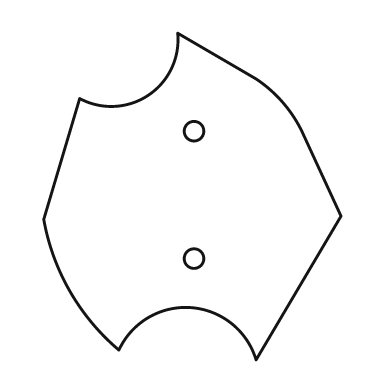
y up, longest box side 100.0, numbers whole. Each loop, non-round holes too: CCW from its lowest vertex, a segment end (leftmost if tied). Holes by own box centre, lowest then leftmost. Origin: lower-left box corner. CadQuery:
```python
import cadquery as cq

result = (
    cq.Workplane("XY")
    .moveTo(65.0, 0.0)
    .lineTo(91.0, 44.0)
    .lineTo(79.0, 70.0)
    .threePointArc((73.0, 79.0), (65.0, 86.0))
    .lineTo(41.0, 100.0)
    .threePointArc((32.0, 81.0), (11.0, 80.0))
    .lineTo(0.0, 43.0)
    .threePointArc((8.0, 21.0), (23.0, 3.0))
    .threePointArc((45.0, 16.0), (65.0, 0.0))
    .close()
    .moveTo(46.0, 31.0)
    .circle(3.0)
    .moveTo(46.0, 70.0)
    .circle(3.0)
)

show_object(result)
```